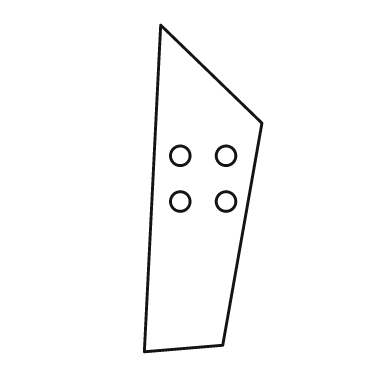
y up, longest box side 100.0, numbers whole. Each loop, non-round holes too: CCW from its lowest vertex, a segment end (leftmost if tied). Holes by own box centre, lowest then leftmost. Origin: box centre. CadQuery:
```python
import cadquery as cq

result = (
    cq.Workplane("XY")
    .moveTo(-18.0, -50.0)
    .lineTo(6.0, -48.0)
    .lineTo(18.0, 20.0)
    .lineTo(-13.0, 50.0)
    .close()
    .moveTo(-7.0, -4.0)
    .circle(3.0)
    .moveTo(7.0, -4.0)
    .circle(3.0)
    .moveTo(-7.0, 10.0)
    .circle(3.0)
    .moveTo(7.0, 10.0)
    .circle(3.0)
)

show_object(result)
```